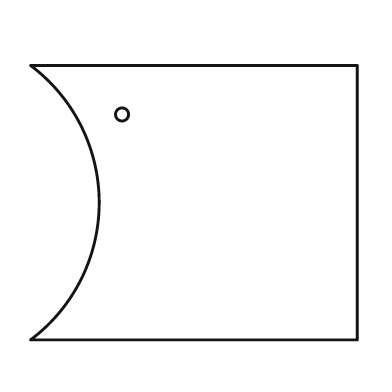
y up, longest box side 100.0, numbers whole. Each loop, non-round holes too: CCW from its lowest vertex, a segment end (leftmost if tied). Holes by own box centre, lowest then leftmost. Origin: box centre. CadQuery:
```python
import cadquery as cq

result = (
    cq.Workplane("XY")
    .moveTo(-50.0, -42.0)
    .lineTo(50.0, -42.0)
    .lineTo(50.0, 42.0)
    .lineTo(-50.0, 42.0)
    .threePointArc((-29.0, 0.0), (-50.0, -42.0))
    .close()
    .moveTo(-22.0, 27.0)
    .circle(2.0)
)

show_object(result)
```